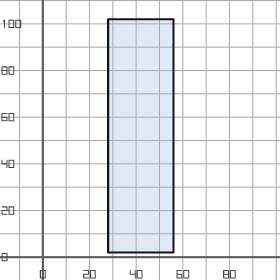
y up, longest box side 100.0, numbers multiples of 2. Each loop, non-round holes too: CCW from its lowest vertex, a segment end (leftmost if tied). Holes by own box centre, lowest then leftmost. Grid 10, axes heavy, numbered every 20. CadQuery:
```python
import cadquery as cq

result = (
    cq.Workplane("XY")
    .moveTo(28.0, 2.0)
    .lineTo(56.0, 2.0)
    .lineTo(56.0, 102.0)
    .lineTo(28.0, 102.0)
    .close()
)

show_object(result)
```